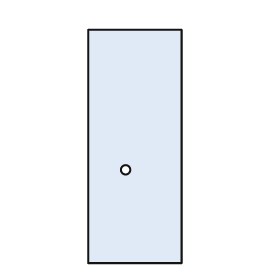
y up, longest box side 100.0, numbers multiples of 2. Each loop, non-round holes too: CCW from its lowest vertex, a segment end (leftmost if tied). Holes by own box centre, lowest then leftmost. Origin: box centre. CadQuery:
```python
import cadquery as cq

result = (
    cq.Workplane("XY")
    .moveTo(-20.0, -50.0)
    .lineTo(20.0, -50.0)
    .lineTo(20.0, 50.0)
    .lineTo(-20.0, 50.0)
    .close()
    .moveTo(-4.0, -10.0)
    .circle(2.0)
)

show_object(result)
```